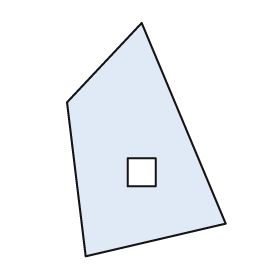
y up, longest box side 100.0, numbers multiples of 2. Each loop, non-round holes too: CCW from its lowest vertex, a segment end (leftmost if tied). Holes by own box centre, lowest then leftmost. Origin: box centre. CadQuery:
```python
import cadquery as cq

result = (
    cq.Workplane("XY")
    .moveTo(-26.0, -50.0)
    .lineTo(34.0, -36.0)
    .lineTo(-2.0, 50.0)
    .lineTo(-34.0, 16.0)
    .close()
    .moveTo(-8.0, -20.0)
    .lineTo(4.0, -20.0)
    .lineTo(4.0, -8.0)
    .lineTo(-8.0, -8.0)
    .close()
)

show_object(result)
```